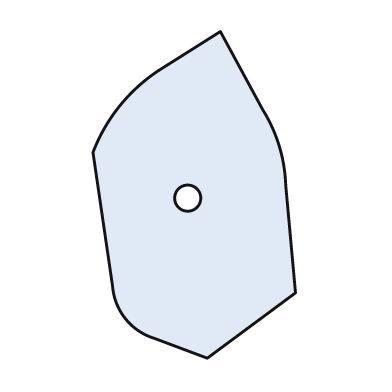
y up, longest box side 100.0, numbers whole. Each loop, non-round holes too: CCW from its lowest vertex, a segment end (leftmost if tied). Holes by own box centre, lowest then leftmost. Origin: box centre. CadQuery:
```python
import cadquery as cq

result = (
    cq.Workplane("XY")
    .moveTo(4.0, -50.0)
    .lineTo(31.0, -30.0)
    .lineTo(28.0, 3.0)
    .threePointArc((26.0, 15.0), (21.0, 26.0))
    .lineTo(8.0, 50.0)
    .lineTo(-11.0, 38.0)
    .threePointArc((-23.0, 27.0), (-31.0, 13.0))
    .lineTo(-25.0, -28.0)
    .threePointArc((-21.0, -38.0), (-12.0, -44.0))
    .close()
    .moveTo(-2.0, -1.0)
    .circle(4.0)
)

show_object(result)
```